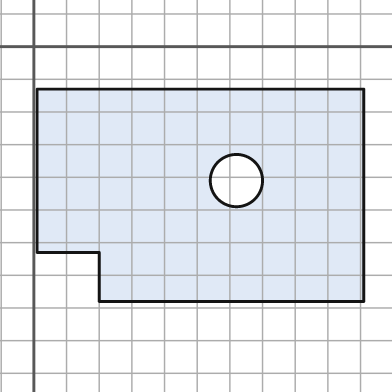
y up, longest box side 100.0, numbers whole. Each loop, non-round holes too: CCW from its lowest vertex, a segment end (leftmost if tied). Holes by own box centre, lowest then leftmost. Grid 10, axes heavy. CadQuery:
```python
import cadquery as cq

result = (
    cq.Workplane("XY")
    .moveTo(20.0, -78.0)
    .lineTo(101.0, -78.0)
    .lineTo(101.0, -13.0)
    .lineTo(1.0, -13.0)
    .lineTo(1.0, -63.0)
    .lineTo(20.0, -63.0)
    .close()
    .moveTo(62.0, -41.0)
    .circle(8.0)
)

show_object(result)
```